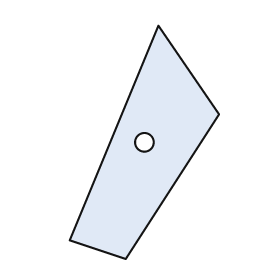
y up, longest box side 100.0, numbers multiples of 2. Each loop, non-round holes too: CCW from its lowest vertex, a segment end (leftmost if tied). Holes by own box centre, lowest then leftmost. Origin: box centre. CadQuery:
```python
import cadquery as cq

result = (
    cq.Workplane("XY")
    .moveTo(-8.0, -50.0)
    .lineTo(32.0, 12.0)
    .lineTo(6.0, 50.0)
    .lineTo(-32.0, -42.0)
    .close()
    .moveTo(0.0, 0.0)
    .circle(4.0)
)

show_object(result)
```